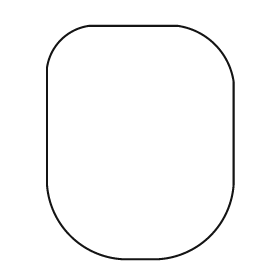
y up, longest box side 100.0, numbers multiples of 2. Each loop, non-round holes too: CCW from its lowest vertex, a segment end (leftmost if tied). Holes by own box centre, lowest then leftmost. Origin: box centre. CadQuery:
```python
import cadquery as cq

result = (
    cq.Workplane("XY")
    .moveTo(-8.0, -50.0)
    .lineTo(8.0, -50.0)
    .threePointArc((30.0, -40.0), (40.0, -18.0))
    .lineTo(40.0, 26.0)
    .threePointArc((32.0, 42.0), (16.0, 50.0))
    .lineTo(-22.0, 50.0)
    .threePointArc((-34.0, 44.0), (-40.0, 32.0))
    .lineTo(-40.0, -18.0)
    .threePointArc((-30.0, -40.0), (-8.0, -50.0))
    .close()
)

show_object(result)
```